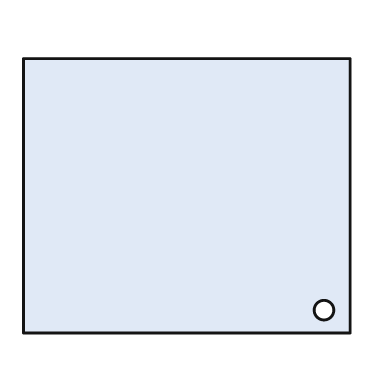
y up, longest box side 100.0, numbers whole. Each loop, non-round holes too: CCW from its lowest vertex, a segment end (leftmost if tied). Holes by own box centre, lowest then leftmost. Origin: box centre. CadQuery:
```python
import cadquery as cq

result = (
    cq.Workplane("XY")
    .moveTo(-50.0, -42.0)
    .lineTo(50.0, -42.0)
    .lineTo(50.0, 42.0)
    .lineTo(-50.0, 42.0)
    .close()
    .moveTo(42.0, -35.0)
    .circle(3.0)
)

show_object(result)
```